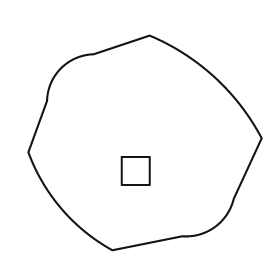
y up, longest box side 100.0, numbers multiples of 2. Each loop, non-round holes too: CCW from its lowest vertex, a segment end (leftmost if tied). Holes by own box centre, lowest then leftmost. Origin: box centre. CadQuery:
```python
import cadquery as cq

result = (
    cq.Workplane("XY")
    .moveTo(-14.0, -46.0)
    .lineTo(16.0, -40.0)
    .threePointArc((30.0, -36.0), (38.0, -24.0))
    .lineTo(50.0, 2.0)
    .threePointArc((30.0, 28.0), (2.0, 46.0))
    .lineTo(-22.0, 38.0)
    .threePointArc((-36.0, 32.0), (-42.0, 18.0))
    .lineTo(-50.0, -4.0)
    .threePointArc((-36.0, -28.0), (-14.0, -46.0))
    .close()
    .moveTo(-10.0, -18.0)
    .lineTo(2.0, -18.0)
    .lineTo(2.0, -6.0)
    .lineTo(-10.0, -6.0)
    .close()
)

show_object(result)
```